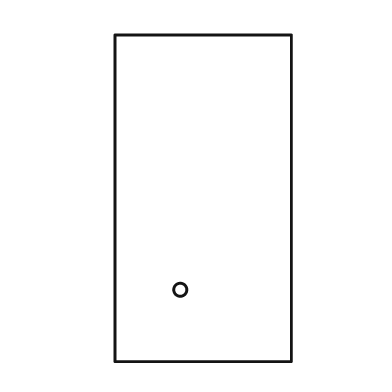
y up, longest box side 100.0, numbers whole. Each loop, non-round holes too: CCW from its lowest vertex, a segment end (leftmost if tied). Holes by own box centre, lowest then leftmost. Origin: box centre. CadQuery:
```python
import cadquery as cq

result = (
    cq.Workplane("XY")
    .moveTo(-27.0, -50.0)
    .lineTo(27.0, -50.0)
    .lineTo(27.0, 50.0)
    .lineTo(-27.0, 50.0)
    .close()
    .moveTo(-7.0, -28.0)
    .circle(2.0)
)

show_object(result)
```